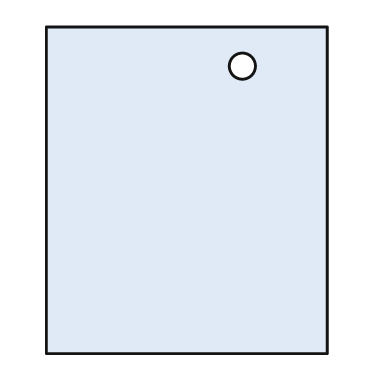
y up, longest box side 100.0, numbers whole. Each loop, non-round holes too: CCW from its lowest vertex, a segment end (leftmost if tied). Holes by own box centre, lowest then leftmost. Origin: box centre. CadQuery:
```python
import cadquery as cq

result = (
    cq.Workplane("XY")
    .moveTo(-43.0, -50.0)
    .lineTo(43.0, -50.0)
    .lineTo(43.0, 50.0)
    .lineTo(-43.0, 50.0)
    .close()
    .moveTo(17.0, 38.0)
    .circle(4.0)
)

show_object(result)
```